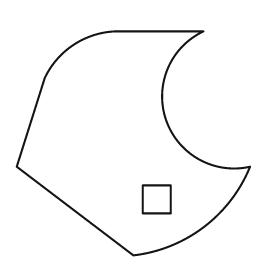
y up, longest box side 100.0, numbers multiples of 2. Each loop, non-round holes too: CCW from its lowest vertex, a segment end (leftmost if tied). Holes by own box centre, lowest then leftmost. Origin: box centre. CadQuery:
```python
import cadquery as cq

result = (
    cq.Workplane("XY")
    .moveTo(0.0, -48.0)
    .threePointArc((30.0, -36.0), (50.0, -10.0))
    .threePointArc((14.0, 10.0), (30.0, 48.0))
    .lineTo(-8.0, 48.0)
    .threePointArc((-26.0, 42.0), (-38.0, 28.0))
    .lineTo(-50.0, -10.0)
    .close()
    .moveTo(4.0, -30.0)
    .lineTo(16.0, -30.0)
    .lineTo(16.0, -18.0)
    .lineTo(4.0, -18.0)
    .close()
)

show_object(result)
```